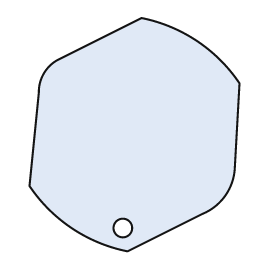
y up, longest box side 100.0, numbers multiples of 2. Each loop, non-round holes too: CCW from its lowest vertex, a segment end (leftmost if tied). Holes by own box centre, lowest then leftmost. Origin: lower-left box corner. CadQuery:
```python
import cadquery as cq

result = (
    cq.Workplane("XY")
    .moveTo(42.0, 0.0)
    .lineTo(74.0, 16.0)
    .threePointArc((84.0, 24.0), (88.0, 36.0))
    .lineTo(90.0, 72.0)
    .threePointArc((72.0, 90.0), (48.0, 100.0))
    .lineTo(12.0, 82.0)
    .threePointArc((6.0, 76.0), (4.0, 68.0))
    .lineTo(0.0, 28.0)
    .threePointArc((18.0, 10.0), (42.0, 0.0))
    .close()
    .moveTo(40.0, 10.0)
    .circle(4.0)
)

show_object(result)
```